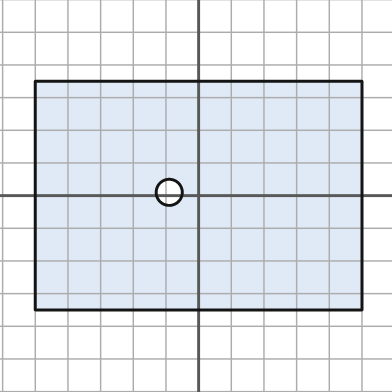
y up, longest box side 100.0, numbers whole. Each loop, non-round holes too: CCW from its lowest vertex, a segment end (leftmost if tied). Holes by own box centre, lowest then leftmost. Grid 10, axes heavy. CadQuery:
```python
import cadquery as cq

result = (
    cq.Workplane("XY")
    .moveTo(-50.0, -35.0)
    .lineTo(50.0, -35.0)
    .lineTo(50.0, 35.0)
    .lineTo(-50.0, 35.0)
    .close()
    .moveTo(-9.0, 1.0)
    .circle(4.0)
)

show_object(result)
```